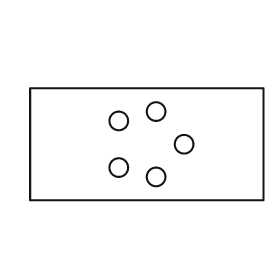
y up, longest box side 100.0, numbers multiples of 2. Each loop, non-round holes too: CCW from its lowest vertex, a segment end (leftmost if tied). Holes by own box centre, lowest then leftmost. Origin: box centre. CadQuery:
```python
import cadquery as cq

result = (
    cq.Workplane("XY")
    .moveTo(-50.0, -24.0)
    .lineTo(50.0, -24.0)
    .lineTo(50.0, 24.0)
    .lineTo(-50.0, 24.0)
    .close()
    .moveTo(4.0, -14.0)
    .circle(4.0)
    .moveTo(-12.0, -10.0)
    .circle(4.0)
    .moveTo(16.0, 0.0)
    .circle(4.0)
    .moveTo(-12.0, 10.0)
    .circle(4.0)
    .moveTo(4.0, 14.0)
    .circle(4.0)
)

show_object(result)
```